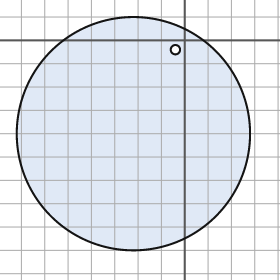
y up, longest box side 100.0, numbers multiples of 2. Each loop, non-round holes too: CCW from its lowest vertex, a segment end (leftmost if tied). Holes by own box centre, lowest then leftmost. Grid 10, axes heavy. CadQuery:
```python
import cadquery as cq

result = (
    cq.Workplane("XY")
    .moveTo(-22.0, -40.0)
    .circle(50.0)
    .moveTo(-4.0, -4.0)
    .circle(2.0)
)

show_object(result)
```